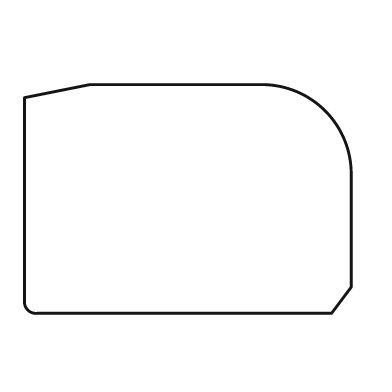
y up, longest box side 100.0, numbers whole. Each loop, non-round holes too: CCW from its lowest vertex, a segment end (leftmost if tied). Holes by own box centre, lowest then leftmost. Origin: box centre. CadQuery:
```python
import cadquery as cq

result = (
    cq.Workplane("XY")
    .moveTo(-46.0, -35.0)
    .lineTo(44.0, -35.0)
    .lineTo(50.0, -27.0)
    .lineTo(50.0, 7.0)
    .threePointArc((42.0, 27.0), (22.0, 35.0))
    .lineTo(-30.0, 35.0)
    .lineTo(-50.0, 31.0)
    .lineTo(-50.0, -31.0)
    .threePointArc((-49.0, -34.0), (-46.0, -35.0))
    .close()
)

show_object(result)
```